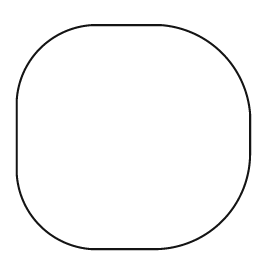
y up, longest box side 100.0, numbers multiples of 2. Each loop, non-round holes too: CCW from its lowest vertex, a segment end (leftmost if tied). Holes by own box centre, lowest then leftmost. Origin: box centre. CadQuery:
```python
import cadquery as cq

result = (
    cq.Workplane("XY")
    .moveTo(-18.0, -48.0)
    .lineTo(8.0, -48.0)
    .threePointArc((38.0, -36.0), (50.0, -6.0))
    .lineTo(50.0, 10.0)
    .threePointArc((38.0, 36.0), (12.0, 48.0))
    .lineTo(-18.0, 48.0)
    .threePointArc((-40.0, 38.0), (-50.0, 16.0))
    .lineTo(-50.0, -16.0)
    .threePointArc((-40.0, -38.0), (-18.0, -48.0))
    .close()
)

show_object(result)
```